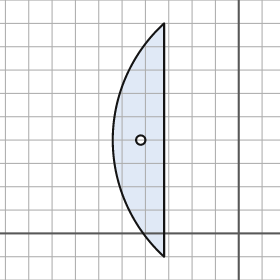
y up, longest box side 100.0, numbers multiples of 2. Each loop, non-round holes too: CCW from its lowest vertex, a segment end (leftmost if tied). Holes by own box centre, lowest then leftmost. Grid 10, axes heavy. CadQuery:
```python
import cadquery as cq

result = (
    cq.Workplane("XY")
    .moveTo(-32.0, -10.0)
    .lineTo(-32.0, 90.0)
    .threePointArc((-54.0, 40.0), (-32.0, -10.0))
    .close()
    .moveTo(-42.0, 40.0)
    .circle(2.0)
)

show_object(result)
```